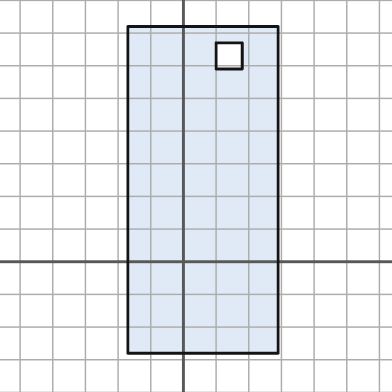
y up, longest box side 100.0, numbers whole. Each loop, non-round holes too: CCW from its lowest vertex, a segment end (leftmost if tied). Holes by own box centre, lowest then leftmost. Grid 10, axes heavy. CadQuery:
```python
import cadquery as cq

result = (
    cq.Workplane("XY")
    .moveTo(-17.0, -28.0)
    .lineTo(29.0, -28.0)
    .lineTo(29.0, 72.0)
    .lineTo(-17.0, 72.0)
    .close()
    .moveTo(10.0, 59.0)
    .lineTo(18.0, 59.0)
    .lineTo(18.0, 67.0)
    .lineTo(10.0, 67.0)
    .close()
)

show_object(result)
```